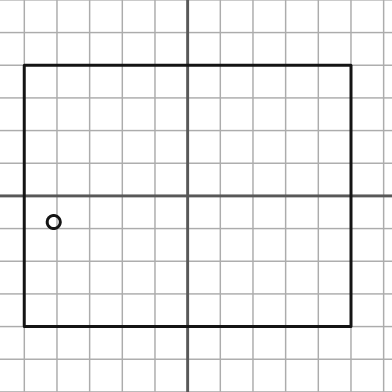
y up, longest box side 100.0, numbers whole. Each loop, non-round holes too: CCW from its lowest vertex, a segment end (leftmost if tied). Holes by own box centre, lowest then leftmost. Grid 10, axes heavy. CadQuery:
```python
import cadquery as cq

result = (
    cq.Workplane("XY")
    .moveTo(-50.0, -40.0)
    .lineTo(50.0, -40.0)
    .lineTo(50.0, 40.0)
    .lineTo(-50.0, 40.0)
    .close()
    .moveTo(-41.0, -8.0)
    .circle(2.0)
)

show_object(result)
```